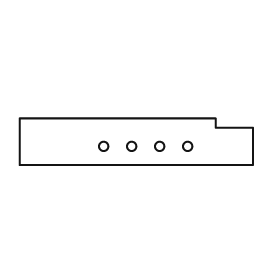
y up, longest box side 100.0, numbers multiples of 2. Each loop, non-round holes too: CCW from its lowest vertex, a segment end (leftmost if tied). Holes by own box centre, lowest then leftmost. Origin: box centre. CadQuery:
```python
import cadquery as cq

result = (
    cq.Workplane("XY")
    .moveTo(-50.0, -10.0)
    .lineTo(50.0, -10.0)
    .lineTo(50.0, 6.0)
    .lineTo(34.0, 6.0)
    .lineTo(34.0, 10.0)
    .lineTo(-50.0, 10.0)
    .close()
    .moveTo(-14.0, -2.0)
    .circle(2.0)
    .moveTo(-2.0, -2.0)
    .circle(2.0)
    .moveTo(10.0, -2.0)
    .circle(2.0)
    .moveTo(22.0, -2.0)
    .circle(2.0)
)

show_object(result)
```